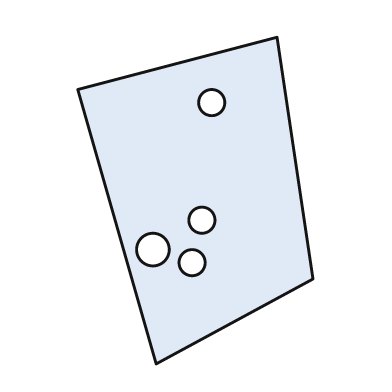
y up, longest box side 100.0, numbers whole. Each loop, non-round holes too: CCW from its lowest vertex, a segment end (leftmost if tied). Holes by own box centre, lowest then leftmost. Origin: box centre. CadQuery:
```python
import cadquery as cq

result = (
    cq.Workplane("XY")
    .moveTo(-12.0, -50.0)
    .lineTo(36.0, -24.0)
    .lineTo(25.0, 50.0)
    .lineTo(-36.0, 34.0)
    .close()
    .moveTo(-1.0, -19.0)
    .circle(4.0)
    .moveTo(-13.0, -15.0)
    .circle(5.0)
    .moveTo(2.0, -6.0)
    .circle(4.0)
    .moveTo(5.0, 30.0)
    .circle(4.0)
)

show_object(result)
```